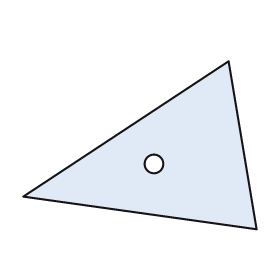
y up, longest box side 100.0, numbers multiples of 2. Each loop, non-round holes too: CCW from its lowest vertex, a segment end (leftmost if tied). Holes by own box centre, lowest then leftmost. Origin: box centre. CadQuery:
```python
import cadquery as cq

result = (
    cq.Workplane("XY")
    .moveTo(50.0, -36.0)
    .lineTo(38.0, 36.0)
    .lineTo(-50.0, -22.0)
    .close()
    .moveTo(6.0, -8.0)
    .circle(4.0)
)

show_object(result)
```